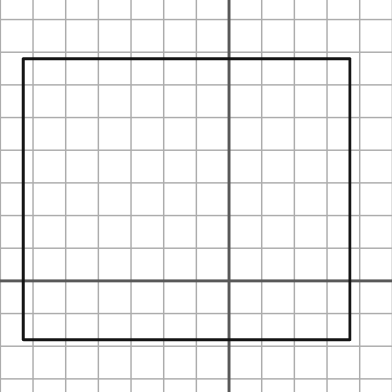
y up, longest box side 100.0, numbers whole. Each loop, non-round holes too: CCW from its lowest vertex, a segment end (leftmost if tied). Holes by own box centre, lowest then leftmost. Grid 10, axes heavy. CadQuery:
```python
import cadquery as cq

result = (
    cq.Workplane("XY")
    .moveTo(-63.0, -18.0)
    .lineTo(37.0, -18.0)
    .lineTo(37.0, 68.0)
    .lineTo(-63.0, 68.0)
    .close()
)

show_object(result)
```